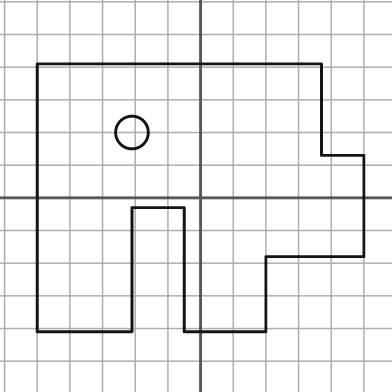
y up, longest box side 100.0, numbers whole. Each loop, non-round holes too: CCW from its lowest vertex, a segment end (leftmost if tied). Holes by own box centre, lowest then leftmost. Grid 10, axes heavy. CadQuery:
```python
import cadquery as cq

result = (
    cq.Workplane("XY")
    .moveTo(-50.0, -41.0)
    .lineTo(-21.0, -41.0)
    .lineTo(-21.0, -3.0)
    .lineTo(-5.0, -3.0)
    .lineTo(-5.0, -41.0)
    .lineTo(20.0, -41.0)
    .lineTo(20.0, -18.0)
    .lineTo(50.0, -18.0)
    .lineTo(50.0, 13.0)
    .lineTo(37.0, 13.0)
    .lineTo(37.0, 41.0)
    .lineTo(-50.0, 41.0)
    .close()
    .moveTo(-21.0, 20.0)
    .circle(5.0)
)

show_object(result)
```